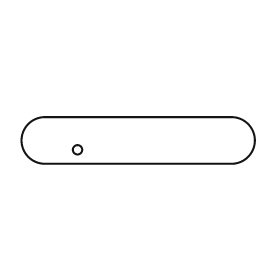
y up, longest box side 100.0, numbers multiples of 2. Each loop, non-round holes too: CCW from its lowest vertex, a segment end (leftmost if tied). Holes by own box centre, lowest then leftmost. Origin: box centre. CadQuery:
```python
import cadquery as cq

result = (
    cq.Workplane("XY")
    .moveTo(-40.0, -10.0)
    .lineTo(40.0, -10.0)
    .threePointArc((50.0, 0.0), (40.0, 10.0))
    .lineTo(-40.0, 10.0)
    .threePointArc((-50.0, 0.0), (-40.0, -10.0))
    .close()
    .moveTo(-26.0, -4.0)
    .circle(2.0)
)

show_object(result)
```